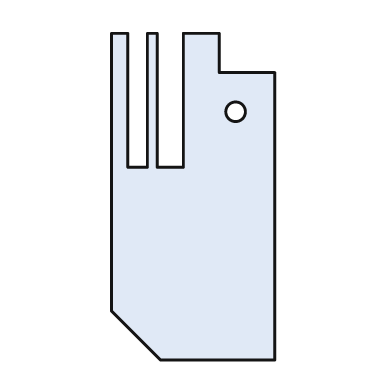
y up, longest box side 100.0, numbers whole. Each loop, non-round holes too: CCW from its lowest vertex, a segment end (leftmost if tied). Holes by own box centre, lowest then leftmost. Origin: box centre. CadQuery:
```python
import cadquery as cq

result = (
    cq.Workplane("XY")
    .moveTo(-10.0, -50.0)
    .lineTo(25.0, -50.0)
    .lineTo(25.0, 38.0)
    .lineTo(8.0, 38.0)
    .lineTo(8.0, 50.0)
    .lineTo(-3.0, 50.0)
    .lineTo(-3.0, 9.0)
    .lineTo(-11.0, 9.0)
    .lineTo(-11.0, 50.0)
    .lineTo(-14.0, 50.0)
    .lineTo(-14.0, 9.0)
    .lineTo(-20.0, 9.0)
    .lineTo(-20.0, 50.0)
    .lineTo(-25.0, 50.0)
    .lineTo(-25.0, -35.0)
    .close()
    .moveTo(13.0, 26.0)
    .circle(3.0)
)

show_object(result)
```